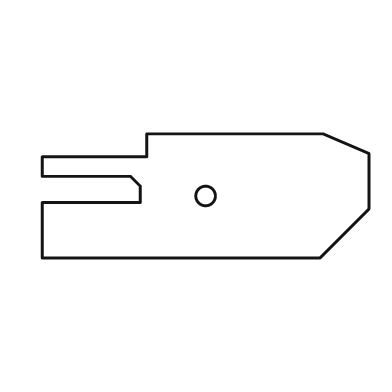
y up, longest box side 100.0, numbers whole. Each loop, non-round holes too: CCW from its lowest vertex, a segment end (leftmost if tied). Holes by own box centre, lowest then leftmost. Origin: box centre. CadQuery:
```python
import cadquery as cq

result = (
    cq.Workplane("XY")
    .moveTo(-50.0, -19.0)
    .lineTo(35.0, -19.0)
    .lineTo(50.0, -4.0)
    .lineTo(50.0, 13.0)
    .lineTo(36.0, 19.0)
    .lineTo(-18.0, 19.0)
    .lineTo(-18.0, 12.0)
    .lineTo(-50.0, 12.0)
    .lineTo(-50.0, 6.0)
    .lineTo(-23.0, 6.0)
    .lineTo(-20.0, 3.0)
    .lineTo(-20.0, -2.0)
    .lineTo(-50.0, -2.0)
    .close()
    .moveTo(0.0, 0.0)
    .circle(3.0)
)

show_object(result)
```